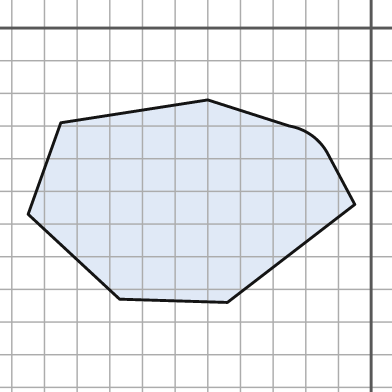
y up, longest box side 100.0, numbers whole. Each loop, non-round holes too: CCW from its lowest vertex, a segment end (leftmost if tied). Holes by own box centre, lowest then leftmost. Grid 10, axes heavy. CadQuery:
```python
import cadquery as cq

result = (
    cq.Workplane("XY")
    .moveTo(-44.0, -84.0)
    .lineTo(-5.0, -54.0)
    .lineTo(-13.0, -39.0)
    .threePointArc((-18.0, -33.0), (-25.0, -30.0))
    .lineTo(-50.0, -22.0)
    .lineTo(-95.0, -29.0)
    .lineTo(-105.0, -57.0)
    .lineTo(-77.0, -83.0)
    .close()
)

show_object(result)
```